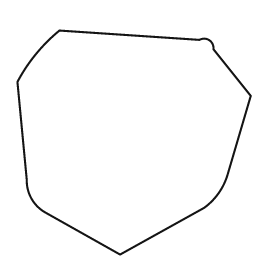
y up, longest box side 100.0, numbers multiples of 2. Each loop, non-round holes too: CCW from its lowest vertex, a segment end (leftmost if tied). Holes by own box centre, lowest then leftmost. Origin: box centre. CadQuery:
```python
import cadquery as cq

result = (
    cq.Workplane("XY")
    .moveTo(-6.0, -48.0)
    .lineTo(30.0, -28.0)
    .threePointArc((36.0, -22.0), (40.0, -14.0))
    .lineTo(50.0, 20.0)
    .lineTo(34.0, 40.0)
    .threePointArc((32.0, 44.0), (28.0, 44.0))
    .lineTo(-32.0, 48.0)
    .threePointArc((-42.0, 38.0), (-50.0, 26.0))
    .lineTo(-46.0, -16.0)
    .threePointArc((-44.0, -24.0), (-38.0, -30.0))
    .close()
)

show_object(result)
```